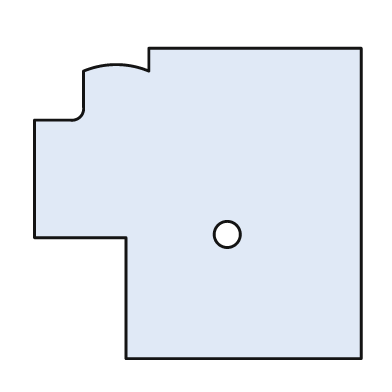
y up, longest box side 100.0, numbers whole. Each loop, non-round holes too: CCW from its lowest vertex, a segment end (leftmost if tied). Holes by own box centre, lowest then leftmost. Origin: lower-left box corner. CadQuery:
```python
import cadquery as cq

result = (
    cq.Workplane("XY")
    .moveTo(28.0, 0.0)
    .lineTo(100.0, 0.0)
    .lineTo(100.0, 95.0)
    .lineTo(35.0, 95.0)
    .lineTo(35.0, 88.0)
    .threePointArc((25.0, 90.0), (15.0, 88.0))
    .lineTo(15.0, 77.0)
    .threePointArc((14.0, 74.0), (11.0, 73.0))
    .lineTo(0.0, 73.0)
    .lineTo(0.0, 37.0)
    .lineTo(28.0, 37.0)
    .close()
    .moveTo(59.0, 38.0)
    .circle(4.0)
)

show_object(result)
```